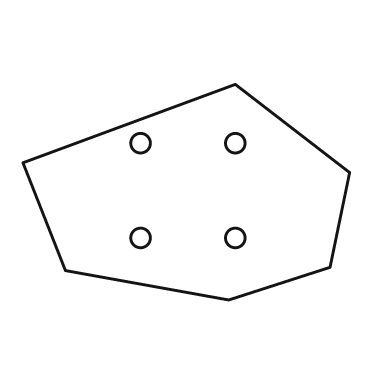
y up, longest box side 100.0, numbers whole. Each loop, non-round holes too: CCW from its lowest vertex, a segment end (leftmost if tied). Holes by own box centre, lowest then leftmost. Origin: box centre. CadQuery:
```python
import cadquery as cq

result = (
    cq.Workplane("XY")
    .moveTo(13.0, -33.0)
    .lineTo(44.0, -23.0)
    .lineTo(50.0, 6.0)
    .lineTo(15.0, 33.0)
    .lineTo(-50.0, 9.0)
    .lineTo(-37.0, -24.0)
    .close()
    .moveTo(-14.0, -14.0)
    .circle(3.0)
    .moveTo(15.0, -14.0)
    .circle(3.0)
    .moveTo(-14.0, 15.0)
    .circle(3.0)
    .moveTo(15.0, 15.0)
    .circle(3.0)
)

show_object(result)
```